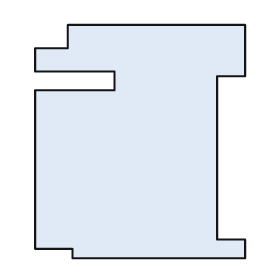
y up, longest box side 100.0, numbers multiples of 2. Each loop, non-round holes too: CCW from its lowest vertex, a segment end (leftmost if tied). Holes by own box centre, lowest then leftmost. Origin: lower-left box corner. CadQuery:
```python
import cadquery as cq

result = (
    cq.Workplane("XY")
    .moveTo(16.0, 0.0)
    .lineTo(90.0, 0.0)
    .lineTo(90.0, 8.0)
    .lineTo(78.0, 8.0)
    .lineTo(78.0, 78.0)
    .lineTo(90.0, 78.0)
    .lineTo(90.0, 100.0)
    .lineTo(14.0, 100.0)
    .lineTo(14.0, 90.0)
    .lineTo(0.0, 90.0)
    .lineTo(0.0, 80.0)
    .lineTo(34.0, 80.0)
    .lineTo(34.0, 72.0)
    .lineTo(0.0, 72.0)
    .lineTo(0.0, 4.0)
    .lineTo(16.0, 4.0)
    .close()
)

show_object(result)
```